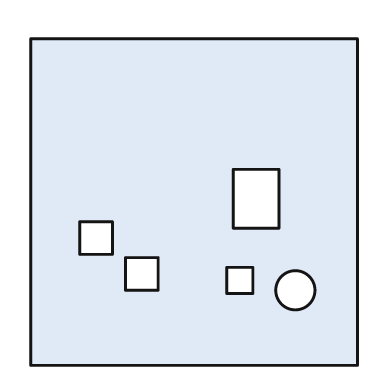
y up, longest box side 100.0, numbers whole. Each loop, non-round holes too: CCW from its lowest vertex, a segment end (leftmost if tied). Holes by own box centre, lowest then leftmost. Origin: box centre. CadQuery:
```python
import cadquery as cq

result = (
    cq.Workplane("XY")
    .moveTo(-50.0, -50.0)
    .lineTo(50.0, -50.0)
    .lineTo(50.0, 50.0)
    .lineTo(-50.0, 50.0)
    .close()
    .moveTo(31.0, -27.0)
    .circle(6.0)
    .moveTo(10.0, -28.0)
    .lineTo(18.0, -28.0)
    .lineTo(18.0, -20.0)
    .lineTo(10.0, -20.0)
    .close()
    .moveTo(-21.0, -27.0)
    .lineTo(-11.0, -27.0)
    .lineTo(-11.0, -17.0)
    .lineTo(-21.0, -17.0)
    .close()
    .moveTo(-35.0, -16.0)
    .lineTo(-25.0, -16.0)
    .lineTo(-25.0, -6.0)
    .lineTo(-35.0, -6.0)
    .close()
    .moveTo(12.0, -8.0)
    .lineTo(26.0, -8.0)
    .lineTo(26.0, 10.0)
    .lineTo(12.0, 10.0)
    .close()
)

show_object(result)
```